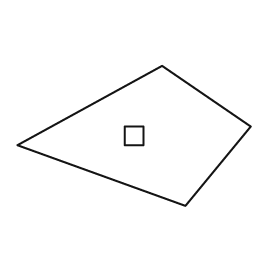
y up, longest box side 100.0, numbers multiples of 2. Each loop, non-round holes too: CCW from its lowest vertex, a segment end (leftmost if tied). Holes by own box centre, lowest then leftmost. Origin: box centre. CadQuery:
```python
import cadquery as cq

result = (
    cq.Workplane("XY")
    .moveTo(22.0, -30.0)
    .lineTo(50.0, 4.0)
    .lineTo(12.0, 30.0)
    .lineTo(-50.0, -4.0)
    .close()
    .moveTo(-4.0, -4.0)
    .lineTo(4.0, -4.0)
    .lineTo(4.0, 4.0)
    .lineTo(-4.0, 4.0)
    .close()
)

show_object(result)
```